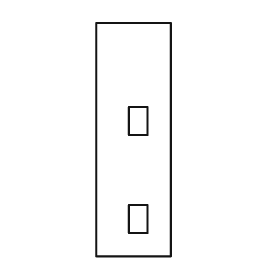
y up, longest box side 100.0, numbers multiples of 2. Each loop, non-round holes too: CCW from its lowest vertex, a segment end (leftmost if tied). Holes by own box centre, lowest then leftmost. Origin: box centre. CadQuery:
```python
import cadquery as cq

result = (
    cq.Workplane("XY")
    .moveTo(-16.0, -50.0)
    .lineTo(16.0, -50.0)
    .lineTo(16.0, 50.0)
    .lineTo(-16.0, 50.0)
    .close()
    .moveTo(-2.0, -40.0)
    .lineTo(6.0, -40.0)
    .lineTo(6.0, -28.0)
    .lineTo(-2.0, -28.0)
    .close()
    .moveTo(-2.0, 2.0)
    .lineTo(6.0, 2.0)
    .lineTo(6.0, 14.0)
    .lineTo(-2.0, 14.0)
    .close()
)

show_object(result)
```